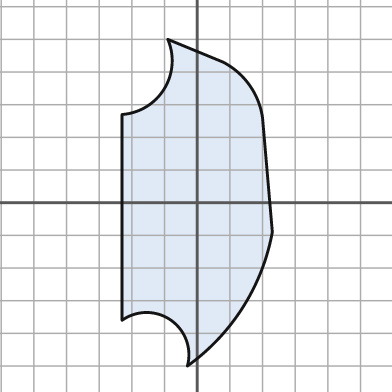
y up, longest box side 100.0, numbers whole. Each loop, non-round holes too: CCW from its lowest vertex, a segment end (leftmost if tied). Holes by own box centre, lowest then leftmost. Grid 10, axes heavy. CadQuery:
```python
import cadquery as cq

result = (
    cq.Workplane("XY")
    .moveTo(-3.0, -50.0)
    .threePointArc((14.0, -32.0), (23.0, -9.0))
    .lineTo(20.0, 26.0)
    .threePointArc((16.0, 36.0), (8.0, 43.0))
    .lineTo(-9.0, 50.0)
    .threePointArc((-10.0, 35.0), (-23.0, 27.0))
    .lineTo(-23.0, -36.0)
    .threePointArc((-8.0, -36.0), (-3.0, -50.0))
    .close()
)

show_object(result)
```